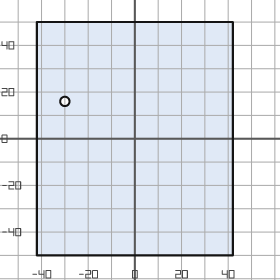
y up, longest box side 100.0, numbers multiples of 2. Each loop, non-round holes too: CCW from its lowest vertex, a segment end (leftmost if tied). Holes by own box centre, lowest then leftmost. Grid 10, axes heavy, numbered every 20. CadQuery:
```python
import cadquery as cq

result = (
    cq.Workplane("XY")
    .moveTo(-42.0, -50.0)
    .lineTo(42.0, -50.0)
    .lineTo(42.0, 50.0)
    .lineTo(-42.0, 50.0)
    .close()
    .moveTo(-30.0, 16.0)
    .circle(2.0)
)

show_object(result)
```